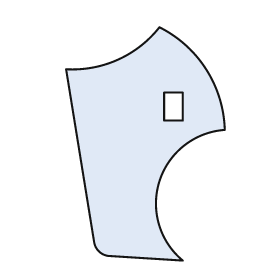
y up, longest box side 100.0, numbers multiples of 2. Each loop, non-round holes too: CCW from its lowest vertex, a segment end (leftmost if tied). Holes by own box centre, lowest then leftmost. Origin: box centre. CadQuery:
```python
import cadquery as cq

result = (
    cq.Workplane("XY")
    .moveTo(16.0, -50.0)
    .threePointArc((6.0, -16.0), (34.0, 6.0))
    .threePointArc((26.0, 32.0), (6.0, 50.0))
    .threePointArc((-12.0, 36.0), (-34.0, 32.0))
    .lineTo(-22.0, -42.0)
    .threePointArc((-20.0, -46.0), (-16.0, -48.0))
    .close()
    .moveTo(8.0, 10.0)
    .lineTo(16.0, 10.0)
    .lineTo(16.0, 22.0)
    .lineTo(8.0, 22.0)
    .close()
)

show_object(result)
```